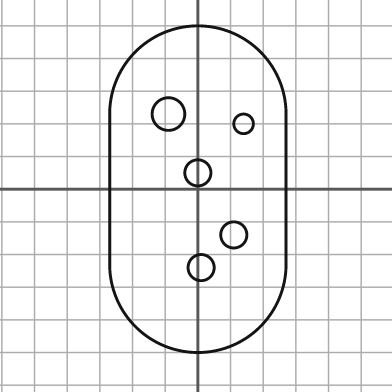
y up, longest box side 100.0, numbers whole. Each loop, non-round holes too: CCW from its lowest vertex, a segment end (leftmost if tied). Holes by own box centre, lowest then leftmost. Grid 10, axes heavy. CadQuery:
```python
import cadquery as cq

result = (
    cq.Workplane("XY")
    .moveTo(-27.0, -23.0)
    .threePointArc((0.0, -50.0), (27.0, -23.0))
    .lineTo(27.0, 23.0)
    .threePointArc((0.0, 50.0), (-27.0, 23.0))
    .close()
    .moveTo(1.0, -24.0)
    .circle(4.0)
    .moveTo(11.0, -14.0)
    .circle(4.0)
    .moveTo(0.0, 5.0)
    .circle(4.0)
    .moveTo(14.0, 20.0)
    .circle(3.0)
    .moveTo(-9.0, 23.0)
    .circle(5.0)
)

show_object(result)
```